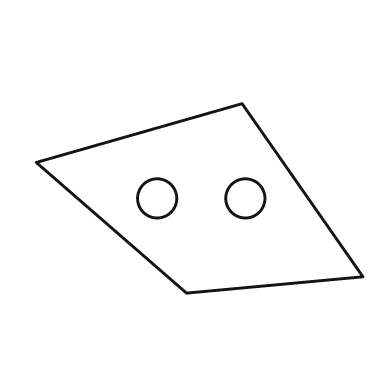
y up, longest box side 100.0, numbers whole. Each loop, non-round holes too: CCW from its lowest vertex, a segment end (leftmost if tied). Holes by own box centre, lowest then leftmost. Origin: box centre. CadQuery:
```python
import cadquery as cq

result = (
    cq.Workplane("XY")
    .moveTo(-4.0, -29.0)
    .lineTo(50.0, -24.0)
    .lineTo(13.0, 29.0)
    .lineTo(-50.0, 11.0)
    .close()
    .moveTo(-13.0, 0.0)
    .circle(6.0)
    .moveTo(14.0, 0.0)
    .circle(6.0)
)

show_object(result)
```